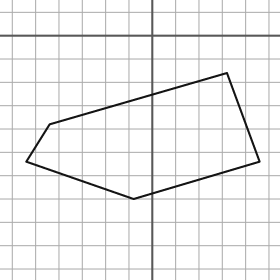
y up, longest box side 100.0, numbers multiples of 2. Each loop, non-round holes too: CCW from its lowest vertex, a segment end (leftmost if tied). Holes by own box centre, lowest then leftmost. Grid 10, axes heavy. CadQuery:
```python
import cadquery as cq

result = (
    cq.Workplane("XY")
    .moveTo(-8.0, -70.0)
    .lineTo(46.0, -54.0)
    .lineTo(32.0, -16.0)
    .lineTo(-44.0, -38.0)
    .lineTo(-54.0, -54.0)
    .close()
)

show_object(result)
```